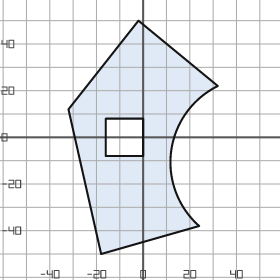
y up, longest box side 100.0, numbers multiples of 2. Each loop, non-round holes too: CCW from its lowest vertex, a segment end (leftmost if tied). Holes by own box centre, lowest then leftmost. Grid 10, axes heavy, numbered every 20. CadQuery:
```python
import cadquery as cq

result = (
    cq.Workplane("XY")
    .moveTo(-18.0, -50.0)
    .lineTo(24.0, -38.0)
    .threePointArc((12.0, -6.0), (32.0, 22.0))
    .lineTo(-2.0, 50.0)
    .lineTo(-32.0, 12.0)
    .close()
    .moveTo(-16.0, -8.0)
    .lineTo(0.0, -8.0)
    .lineTo(0.0, 8.0)
    .lineTo(-16.0, 8.0)
    .close()
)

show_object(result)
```